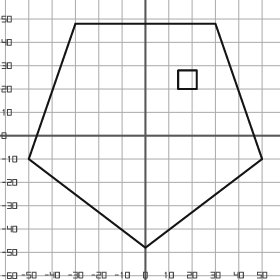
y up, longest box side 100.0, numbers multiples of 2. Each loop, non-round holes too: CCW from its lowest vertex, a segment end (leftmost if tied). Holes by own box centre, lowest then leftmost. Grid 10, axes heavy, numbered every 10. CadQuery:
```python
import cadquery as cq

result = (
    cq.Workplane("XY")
    .moveTo(0.0, -48.0)
    .lineTo(50.0, -10.0)
    .lineTo(30.0, 48.0)
    .lineTo(-30.0, 48.0)
    .lineTo(-50.0, -10.0)
    .close()
    .moveTo(14.0, 20.0)
    .lineTo(22.0, 20.0)
    .lineTo(22.0, 28.0)
    .lineTo(14.0, 28.0)
    .close()
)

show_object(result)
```